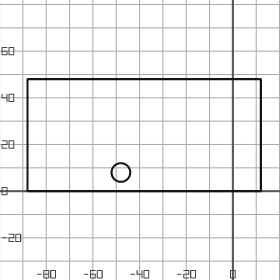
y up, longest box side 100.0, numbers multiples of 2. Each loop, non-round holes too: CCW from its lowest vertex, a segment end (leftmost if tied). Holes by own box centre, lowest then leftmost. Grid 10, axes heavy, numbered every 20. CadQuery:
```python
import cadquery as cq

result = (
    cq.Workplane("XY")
    .moveTo(-88.0, 0.0)
    .lineTo(12.0, 0.0)
    .lineTo(12.0, 48.0)
    .lineTo(-88.0, 48.0)
    .close()
    .moveTo(-48.0, 8.0)
    .circle(4.0)
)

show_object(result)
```